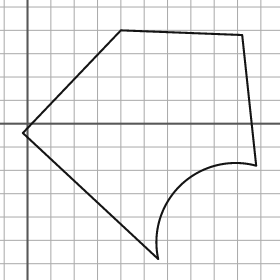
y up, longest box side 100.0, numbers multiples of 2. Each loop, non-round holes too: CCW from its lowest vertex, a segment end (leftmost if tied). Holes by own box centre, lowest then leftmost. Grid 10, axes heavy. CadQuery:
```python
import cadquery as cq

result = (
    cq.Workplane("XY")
    .moveTo(56.0, -58.0)
    .threePointArc((66.0, -26.0), (98.0, -18.0))
    .lineTo(92.0, 38.0)
    .lineTo(40.0, 40.0)
    .lineTo(-2.0, -4.0)
    .close()
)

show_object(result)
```